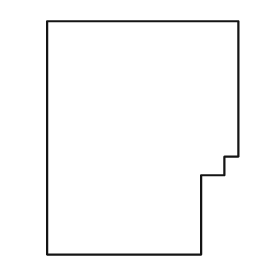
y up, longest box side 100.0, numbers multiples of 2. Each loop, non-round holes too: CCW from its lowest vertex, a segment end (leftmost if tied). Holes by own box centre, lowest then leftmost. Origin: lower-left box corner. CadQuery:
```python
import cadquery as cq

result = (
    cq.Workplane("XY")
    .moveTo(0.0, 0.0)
    .lineTo(66.0, 0.0)
    .lineTo(66.0, 34.0)
    .lineTo(76.0, 34.0)
    .lineTo(76.0, 42.0)
    .lineTo(82.0, 42.0)
    .lineTo(82.0, 100.0)
    .lineTo(0.0, 100.0)
    .close()
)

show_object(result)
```